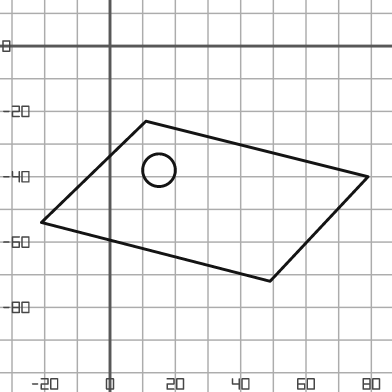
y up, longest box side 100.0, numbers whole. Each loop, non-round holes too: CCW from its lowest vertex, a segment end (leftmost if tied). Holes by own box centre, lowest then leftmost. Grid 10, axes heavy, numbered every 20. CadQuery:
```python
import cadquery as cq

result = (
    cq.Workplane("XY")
    .moveTo(49.0, -72.0)
    .lineTo(79.0, -40.0)
    .lineTo(11.0, -23.0)
    .lineTo(-21.0, -54.0)
    .close()
    .moveTo(15.0, -38.0)
    .circle(5.0)
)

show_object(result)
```